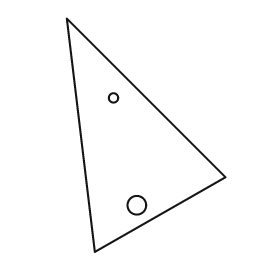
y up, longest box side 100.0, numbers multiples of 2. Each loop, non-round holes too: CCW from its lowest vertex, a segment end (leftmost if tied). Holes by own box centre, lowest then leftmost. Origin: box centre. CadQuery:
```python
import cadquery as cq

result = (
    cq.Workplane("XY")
    .moveTo(-22.0, -50.0)
    .lineTo(34.0, -18.0)
    .lineTo(-34.0, 50.0)
    .close()
    .moveTo(-4.0, -30.0)
    .circle(4.0)
    .moveTo(-14.0, 16.0)
    .circle(2.0)
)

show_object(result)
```